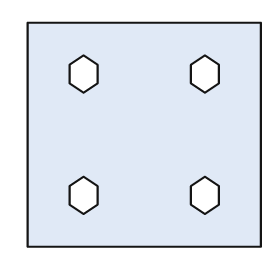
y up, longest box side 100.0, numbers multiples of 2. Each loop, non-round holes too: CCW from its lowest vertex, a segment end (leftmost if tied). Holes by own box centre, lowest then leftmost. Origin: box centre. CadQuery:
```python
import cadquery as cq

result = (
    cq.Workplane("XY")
    .moveTo(-50.0, -48.0)
    .lineTo(50.0, -48.0)
    .lineTo(50.0, 48.0)
    .lineTo(-50.0, 48.0)
    .close()
    .moveTo(-26.0, -34.0)
    .lineTo(-20.0, -30.0)
    .lineTo(-20.0, -22.0)
    .lineTo(-26.0, -18.0)
    .lineTo(-32.0, -22.0)
    .lineTo(-32.0, -30.0)
    .close()
    .moveTo(26.0, -34.0)
    .lineTo(32.0, -30.0)
    .lineTo(32.0, -22.0)
    .lineTo(26.0, -18.0)
    .lineTo(20.0, -22.0)
    .lineTo(20.0, -30.0)
    .close()
    .moveTo(-26.0, 18.0)
    .lineTo(-20.0, 22.0)
    .lineTo(-20.0, 30.0)
    .lineTo(-26.0, 34.0)
    .lineTo(-32.0, 30.0)
    .lineTo(-32.0, 22.0)
    .close()
    .moveTo(26.0, 18.0)
    .lineTo(32.0, 22.0)
    .lineTo(32.0, 30.0)
    .lineTo(26.0, 34.0)
    .lineTo(20.0, 30.0)
    .lineTo(20.0, 22.0)
    .close()
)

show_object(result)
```